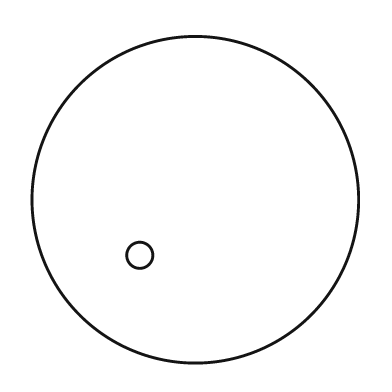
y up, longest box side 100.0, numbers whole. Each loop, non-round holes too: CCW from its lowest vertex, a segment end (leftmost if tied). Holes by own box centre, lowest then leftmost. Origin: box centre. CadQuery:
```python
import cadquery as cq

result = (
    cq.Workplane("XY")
    .moveTo(0.0, 0.0)
    .circle(50.0)
    .moveTo(-17.0, -17.0)
    .circle(4.0)
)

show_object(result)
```